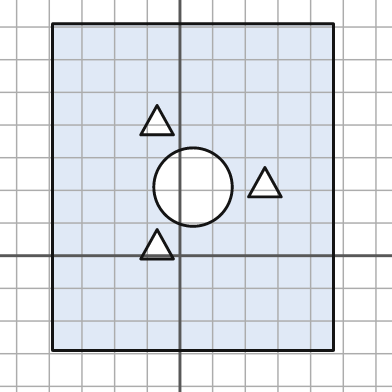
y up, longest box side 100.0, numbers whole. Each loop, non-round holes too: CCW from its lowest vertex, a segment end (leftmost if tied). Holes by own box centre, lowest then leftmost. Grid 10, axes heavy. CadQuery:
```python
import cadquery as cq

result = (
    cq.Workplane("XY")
    .moveTo(-39.0, -29.0)
    .lineTo(47.0, -29.0)
    .lineTo(47.0, 71.0)
    .lineTo(-39.0, 71.0)
    .close()
    .moveTo(-12.0, -1.0)
    .lineTo(-2.0, -1.0)
    .lineTo(-7.0, 8.0)
    .close()
    .moveTo(4.0, 21.0)
    .circle(12.0)
    .moveTo(21.0, 18.0)
    .lineTo(31.0, 18.0)
    .lineTo(26.0, 27.0)
    .close()
    .moveTo(-12.0, 37.0)
    .lineTo(-2.0, 37.0)
    .lineTo(-7.0, 46.0)
    .close()
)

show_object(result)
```